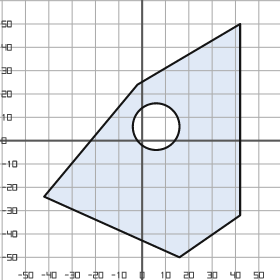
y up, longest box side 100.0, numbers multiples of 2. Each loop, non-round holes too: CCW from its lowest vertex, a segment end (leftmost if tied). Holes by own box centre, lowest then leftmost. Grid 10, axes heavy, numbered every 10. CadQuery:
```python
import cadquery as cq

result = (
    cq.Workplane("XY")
    .moveTo(16.0, -50.0)
    .lineTo(42.0, -32.0)
    .lineTo(42.0, 50.0)
    .lineTo(-2.0, 24.0)
    .lineTo(-42.0, -24.0)
    .close()
    .moveTo(6.0, 6.0)
    .circle(10.0)
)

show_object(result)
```